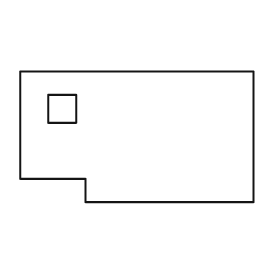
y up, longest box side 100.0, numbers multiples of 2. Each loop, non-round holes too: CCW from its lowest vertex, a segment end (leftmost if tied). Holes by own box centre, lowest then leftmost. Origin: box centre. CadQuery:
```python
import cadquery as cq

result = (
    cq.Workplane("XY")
    .moveTo(-22.0, -28.0)
    .lineTo(50.0, -28.0)
    .lineTo(50.0, 28.0)
    .lineTo(-50.0, 28.0)
    .lineTo(-50.0, -18.0)
    .lineTo(-22.0, -18.0)
    .close()
    .moveTo(-38.0, 6.0)
    .lineTo(-26.0, 6.0)
    .lineTo(-26.0, 18.0)
    .lineTo(-38.0, 18.0)
    .close()
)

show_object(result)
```